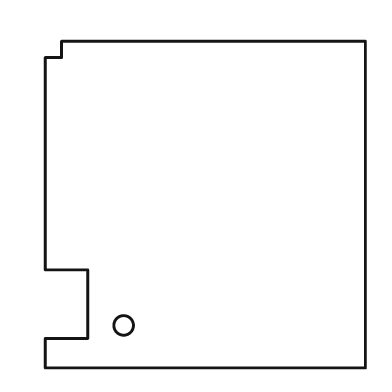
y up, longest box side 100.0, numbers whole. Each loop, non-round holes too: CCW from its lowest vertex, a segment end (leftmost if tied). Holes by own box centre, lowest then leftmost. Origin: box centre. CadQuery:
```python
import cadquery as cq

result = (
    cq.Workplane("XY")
    .moveTo(-49.0, -50.0)
    .lineTo(49.0, -50.0)
    .lineTo(49.0, 50.0)
    .lineTo(-44.0, 50.0)
    .lineTo(-44.0, 45.0)
    .lineTo(-49.0, 45.0)
    .lineTo(-49.0, -20.0)
    .lineTo(-36.0, -20.0)
    .lineTo(-36.0, -41.0)
    .lineTo(-49.0, -41.0)
    .close()
    .moveTo(-25.0, -37.0)
    .circle(3.0)
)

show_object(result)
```